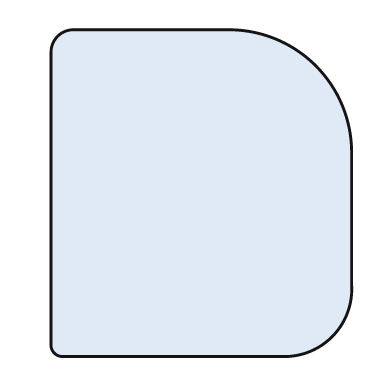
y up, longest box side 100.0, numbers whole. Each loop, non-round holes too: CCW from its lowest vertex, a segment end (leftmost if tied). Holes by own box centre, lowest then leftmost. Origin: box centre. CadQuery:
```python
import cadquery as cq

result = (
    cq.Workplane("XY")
    .moveTo(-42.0, -50.0)
    .lineTo(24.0, -50.0)
    .threePointArc((40.0, -44.0), (46.0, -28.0))
    .lineTo(46.0, 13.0)
    .threePointArc((35.0, 39.0), (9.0, 50.0))
    .lineTo(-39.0, 50.0)
    .threePointArc((-44.0, 48.0), (-46.0, 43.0))
    .lineTo(-46.0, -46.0)
    .threePointArc((-45.0, -49.0), (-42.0, -50.0))
    .close()
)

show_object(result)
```